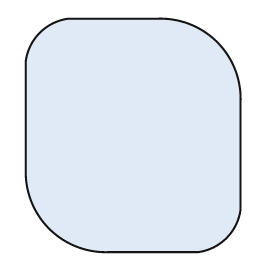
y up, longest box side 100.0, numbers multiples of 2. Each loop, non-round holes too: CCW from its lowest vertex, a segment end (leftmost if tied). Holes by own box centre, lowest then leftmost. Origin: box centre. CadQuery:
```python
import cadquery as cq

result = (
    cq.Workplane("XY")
    .moveTo(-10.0, -50.0)
    .lineTo(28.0, -50.0)
    .threePointArc((40.0, -44.0), (46.0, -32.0))
    .lineTo(46.0, 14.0)
    .threePointArc((36.0, 40.0), (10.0, 50.0))
    .lineTo(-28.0, 50.0)
    .threePointArc((-40.0, 44.0), (-46.0, 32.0))
    .lineTo(-46.0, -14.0)
    .threePointArc((-36.0, -40.0), (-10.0, -50.0))
    .close()
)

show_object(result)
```